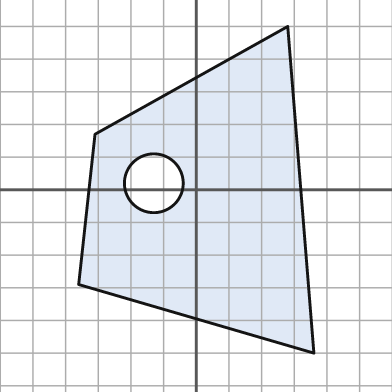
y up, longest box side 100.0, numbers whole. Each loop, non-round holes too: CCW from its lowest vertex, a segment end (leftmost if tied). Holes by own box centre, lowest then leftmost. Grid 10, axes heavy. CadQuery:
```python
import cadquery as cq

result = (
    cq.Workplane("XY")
    .moveTo(36.0, -50.0)
    .lineTo(28.0, 50.0)
    .lineTo(-31.0, 17.0)
    .lineTo(-36.0, -29.0)
    .close()
    .moveTo(-13.0, 2.0)
    .circle(9.0)
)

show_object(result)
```